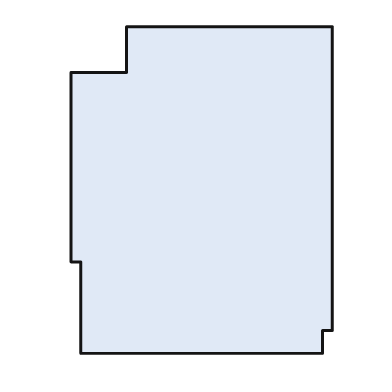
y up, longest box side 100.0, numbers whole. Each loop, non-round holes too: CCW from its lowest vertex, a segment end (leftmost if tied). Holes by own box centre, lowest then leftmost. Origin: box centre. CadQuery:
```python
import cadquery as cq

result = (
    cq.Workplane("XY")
    .moveTo(-37.0, -50.0)
    .lineTo(37.0, -50.0)
    .lineTo(37.0, -43.0)
    .lineTo(40.0, -43.0)
    .lineTo(40.0, 50.0)
    .lineTo(-23.0, 50.0)
    .lineTo(-23.0, 36.0)
    .lineTo(-40.0, 36.0)
    .lineTo(-40.0, -22.0)
    .lineTo(-37.0, -22.0)
    .close()
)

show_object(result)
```